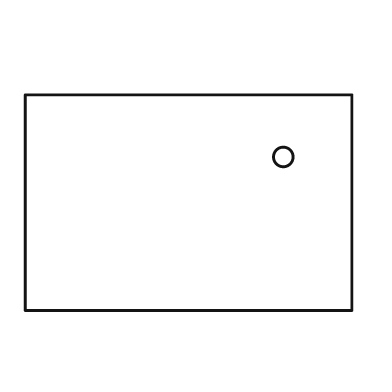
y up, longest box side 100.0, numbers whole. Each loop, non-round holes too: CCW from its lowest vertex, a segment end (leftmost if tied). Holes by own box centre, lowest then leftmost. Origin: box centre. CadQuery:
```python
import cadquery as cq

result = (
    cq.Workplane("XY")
    .moveTo(-50.0, -33.0)
    .lineTo(50.0, -33.0)
    .lineTo(50.0, 33.0)
    .lineTo(-50.0, 33.0)
    .close()
    .moveTo(29.0, 14.0)
    .circle(3.0)
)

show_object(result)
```